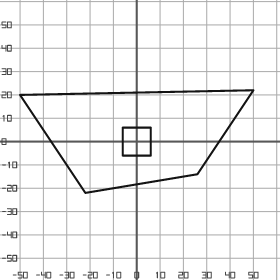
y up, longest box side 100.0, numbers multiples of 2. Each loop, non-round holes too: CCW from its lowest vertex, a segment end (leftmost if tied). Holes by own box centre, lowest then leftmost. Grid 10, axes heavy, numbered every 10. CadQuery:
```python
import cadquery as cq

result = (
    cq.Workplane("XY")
    .moveTo(-22.0, -22.0)
    .lineTo(26.0, -14.0)
    .lineTo(50.0, 22.0)
    .lineTo(-50.0, 20.0)
    .close()
    .moveTo(-6.0, -6.0)
    .lineTo(6.0, -6.0)
    .lineTo(6.0, 6.0)
    .lineTo(-6.0, 6.0)
    .close()
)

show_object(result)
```